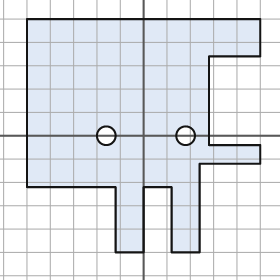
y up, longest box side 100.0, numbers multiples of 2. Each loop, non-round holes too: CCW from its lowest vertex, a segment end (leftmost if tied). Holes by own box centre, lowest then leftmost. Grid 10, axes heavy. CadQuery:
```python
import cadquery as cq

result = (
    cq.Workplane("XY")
    .moveTo(-12.0, -50.0)
    .lineTo(0.0, -50.0)
    .lineTo(0.0, -22.0)
    .lineTo(12.0, -22.0)
    .lineTo(12.0, -50.0)
    .lineTo(24.0, -50.0)
    .lineTo(24.0, -12.0)
    .lineTo(50.0, -12.0)
    .lineTo(50.0, -4.0)
    .lineTo(28.0, -4.0)
    .lineTo(28.0, 34.0)
    .lineTo(50.0, 34.0)
    .lineTo(50.0, 50.0)
    .lineTo(-50.0, 50.0)
    .lineTo(-50.0, -22.0)
    .lineTo(-12.0, -22.0)
    .close()
    .moveTo(-16.0, 0.0)
    .circle(4.0)
    .moveTo(18.0, 0.0)
    .circle(4.0)
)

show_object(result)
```